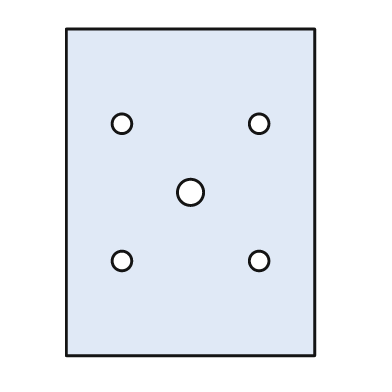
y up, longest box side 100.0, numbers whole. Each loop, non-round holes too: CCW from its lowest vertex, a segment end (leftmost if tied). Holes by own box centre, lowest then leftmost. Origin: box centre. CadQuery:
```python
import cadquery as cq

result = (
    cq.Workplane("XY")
    .moveTo(-38.0, -50.0)
    .lineTo(38.0, -50.0)
    .lineTo(38.0, 50.0)
    .lineTo(-38.0, 50.0)
    .close()
    .moveTo(-21.0, -21.0)
    .circle(3.0)
    .moveTo(21.0, -21.0)
    .circle(3.0)
    .moveTo(0.0, 0.0)
    .circle(4.0)
    .moveTo(-21.0, 21.0)
    .circle(3.0)
    .moveTo(21.0, 21.0)
    .circle(3.0)
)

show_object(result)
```